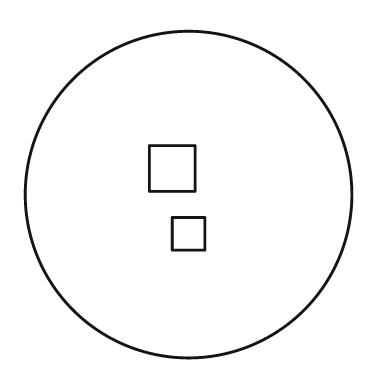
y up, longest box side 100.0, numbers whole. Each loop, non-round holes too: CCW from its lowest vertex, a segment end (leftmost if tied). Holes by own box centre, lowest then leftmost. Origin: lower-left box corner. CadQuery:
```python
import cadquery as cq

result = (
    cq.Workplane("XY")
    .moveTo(50.0, 50.0)
    .circle(50.0)
    .moveTo(45.0, 33.0)
    .lineTo(55.0, 33.0)
    .lineTo(55.0, 43.0)
    .lineTo(45.0, 43.0)
    .close()
    .moveTo(38.0, 51.0)
    .lineTo(52.0, 51.0)
    .lineTo(52.0, 65.0)
    .lineTo(38.0, 65.0)
    .close()
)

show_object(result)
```